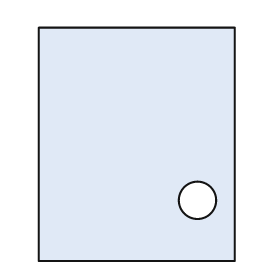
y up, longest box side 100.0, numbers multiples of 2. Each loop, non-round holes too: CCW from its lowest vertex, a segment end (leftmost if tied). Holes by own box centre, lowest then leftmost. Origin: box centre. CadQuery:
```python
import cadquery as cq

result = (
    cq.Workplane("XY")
    .moveTo(-42.0, -50.0)
    .lineTo(42.0, -50.0)
    .lineTo(42.0, 50.0)
    .lineTo(-42.0, 50.0)
    .close()
    .moveTo(26.0, -24.0)
    .circle(8.0)
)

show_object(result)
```